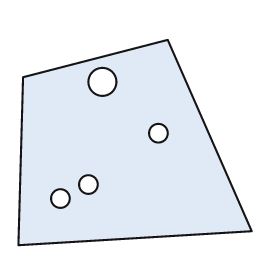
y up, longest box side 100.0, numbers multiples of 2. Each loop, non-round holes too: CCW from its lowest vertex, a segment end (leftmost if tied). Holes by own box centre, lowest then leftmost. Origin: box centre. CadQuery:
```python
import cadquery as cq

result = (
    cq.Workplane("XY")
    .moveTo(-50.0, -44.0)
    .lineTo(50.0, -38.0)
    .lineTo(14.0, 44.0)
    .lineTo(-48.0, 28.0)
    .close()
    .moveTo(-32.0, -24.0)
    .circle(4.0)
    .moveTo(-20.0, -18.0)
    .circle(4.0)
    .moveTo(10.0, 4.0)
    .circle(4.0)
    .moveTo(-14.0, 26.0)
    .circle(6.0)
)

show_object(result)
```